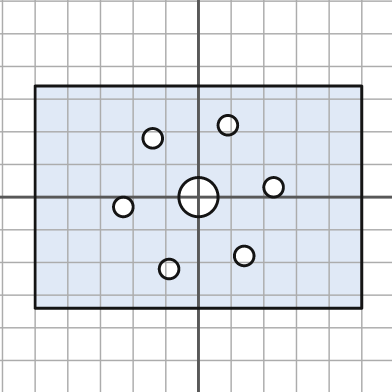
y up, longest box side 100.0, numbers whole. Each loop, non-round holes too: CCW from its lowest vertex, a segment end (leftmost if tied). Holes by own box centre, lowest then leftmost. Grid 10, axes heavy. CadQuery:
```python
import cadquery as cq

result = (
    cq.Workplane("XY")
    .moveTo(-50.0, -34.0)
    .lineTo(50.0, -34.0)
    .lineTo(50.0, 34.0)
    .lineTo(-50.0, 34.0)
    .close()
    .moveTo(-9.0, -22.0)
    .circle(3.0)
    .moveTo(14.0, -18.0)
    .circle(3.0)
    .moveTo(-23.0, -3.0)
    .circle(3.0)
    .moveTo(0.0, 0.0)
    .circle(6.0)
    .moveTo(23.0, 3.0)
    .circle(3.0)
    .moveTo(-14.0, 18.0)
    .circle(3.0)
    .moveTo(9.0, 22.0)
    .circle(3.0)
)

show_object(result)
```